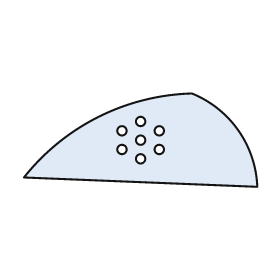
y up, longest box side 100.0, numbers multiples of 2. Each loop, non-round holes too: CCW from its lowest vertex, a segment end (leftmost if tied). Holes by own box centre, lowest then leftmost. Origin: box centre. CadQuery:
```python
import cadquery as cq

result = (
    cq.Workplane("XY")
    .moveTo(50.0, -20.0)
    .threePointArc((42.0, 4.0), (22.0, 20.0))
    .threePointArc((-18.0, 10.0), (-50.0, -16.0))
    .close()
    .moveTo(0.0, -8.0)
    .circle(2.0)
    .moveTo(-8.0, -4.0)
    .circle(2.0)
    .moveTo(8.0, -4.0)
    .circle(2.0)
    .moveTo(0.0, 0.0)
    .circle(2.0)
    .moveTo(-8.0, 4.0)
    .circle(2.0)
    .moveTo(8.0, 4.0)
    .circle(2.0)
    .moveTo(0.0, 8.0)
    .circle(2.0)
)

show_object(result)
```